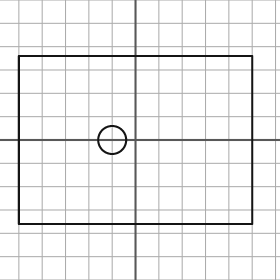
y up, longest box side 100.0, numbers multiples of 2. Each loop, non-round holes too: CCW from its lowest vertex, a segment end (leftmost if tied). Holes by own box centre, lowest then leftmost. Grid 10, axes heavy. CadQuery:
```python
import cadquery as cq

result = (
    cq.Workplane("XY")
    .moveTo(-50.0, -36.0)
    .lineTo(50.0, -36.0)
    .lineTo(50.0, 36.0)
    .lineTo(-50.0, 36.0)
    .close()
    .moveTo(-10.0, 0.0)
    .circle(6.0)
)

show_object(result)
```